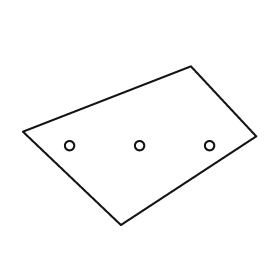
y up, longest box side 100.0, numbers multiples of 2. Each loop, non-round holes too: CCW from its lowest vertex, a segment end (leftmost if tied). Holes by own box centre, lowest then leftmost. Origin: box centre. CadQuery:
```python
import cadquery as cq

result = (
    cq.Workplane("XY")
    .moveTo(-8.0, -34.0)
    .lineTo(50.0, 4.0)
    .lineTo(22.0, 34.0)
    .lineTo(-50.0, 6.0)
    .close()
    .moveTo(-30.0, 0.0)
    .circle(2.0)
    .moveTo(0.0, 0.0)
    .circle(2.0)
    .moveTo(30.0, 0.0)
    .circle(2.0)
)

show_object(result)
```